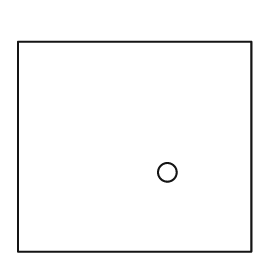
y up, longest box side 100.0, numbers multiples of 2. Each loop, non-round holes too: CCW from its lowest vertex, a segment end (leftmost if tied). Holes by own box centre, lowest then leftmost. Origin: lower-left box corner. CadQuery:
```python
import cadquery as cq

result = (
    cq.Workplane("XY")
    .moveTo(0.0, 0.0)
    .lineTo(100.0, 0.0)
    .lineTo(100.0, 90.0)
    .lineTo(0.0, 90.0)
    .close()
    .moveTo(64.0, 34.0)
    .circle(4.0)
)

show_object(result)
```